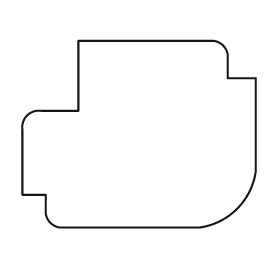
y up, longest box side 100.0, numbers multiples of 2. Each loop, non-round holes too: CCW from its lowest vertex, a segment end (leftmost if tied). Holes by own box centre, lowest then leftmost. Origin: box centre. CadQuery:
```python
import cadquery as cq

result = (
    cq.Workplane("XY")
    .moveTo(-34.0, -40.0)
    .lineTo(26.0, -40.0)
    .threePointArc((42.0, -32.0), (50.0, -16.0))
    .lineTo(50.0, 24.0)
    .lineTo(38.0, 24.0)
    .lineTo(38.0, 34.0)
    .threePointArc((36.0, 38.0), (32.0, 40.0))
    .lineTo(-26.0, 40.0)
    .lineTo(-26.0, 10.0)
    .lineTo(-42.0, 10.0)
    .threePointArc((-48.0, 8.0), (-50.0, 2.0))
    .lineTo(-50.0, -26.0)
    .lineTo(-40.0, -26.0)
    .lineTo(-40.0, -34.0)
    .threePointArc((-38.0, -38.0), (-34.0, -40.0))
    .close()
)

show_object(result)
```